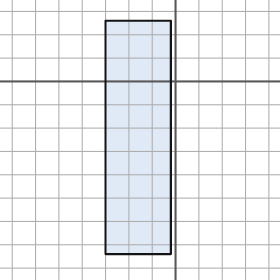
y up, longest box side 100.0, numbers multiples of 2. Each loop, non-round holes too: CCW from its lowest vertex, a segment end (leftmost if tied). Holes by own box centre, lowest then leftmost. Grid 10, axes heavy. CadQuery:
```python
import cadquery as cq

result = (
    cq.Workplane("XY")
    .moveTo(-30.0, -74.0)
    .lineTo(-2.0, -74.0)
    .lineTo(-2.0, 26.0)
    .lineTo(-30.0, 26.0)
    .close()
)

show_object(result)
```